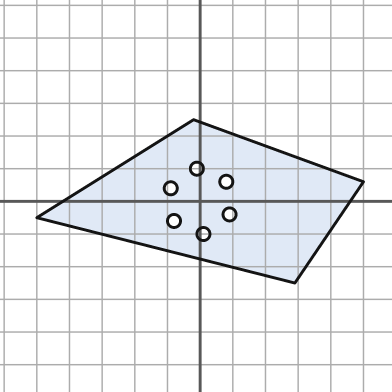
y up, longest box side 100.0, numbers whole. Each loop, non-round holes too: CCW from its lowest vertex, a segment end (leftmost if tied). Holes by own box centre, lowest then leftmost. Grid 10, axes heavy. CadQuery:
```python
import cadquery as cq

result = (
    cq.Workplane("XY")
    .moveTo(29.0, -25.0)
    .lineTo(50.0, 6.0)
    .lineTo(-2.0, 25.0)
    .lineTo(-50.0, -5.0)
    .close()
    .moveTo(1.0, -10.0)
    .circle(2.0)
    .moveTo(-8.0, -6.0)
    .circle(2.0)
    .moveTo(9.0, -4.0)
    .circle(2.0)
    .moveTo(-9.0, 4.0)
    .circle(2.0)
    .moveTo(8.0, 6.0)
    .circle(2.0)
    .moveTo(-1.0, 10.0)
    .circle(2.0)
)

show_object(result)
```